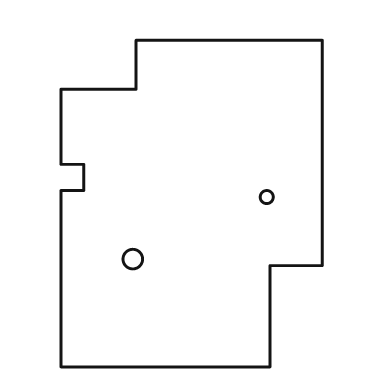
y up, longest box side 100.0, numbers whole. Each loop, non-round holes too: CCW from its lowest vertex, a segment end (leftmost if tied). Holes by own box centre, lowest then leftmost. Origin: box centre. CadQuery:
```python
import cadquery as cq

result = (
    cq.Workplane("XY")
    .moveTo(-40.0, -50.0)
    .lineTo(24.0, -50.0)
    .lineTo(24.0, -19.0)
    .lineTo(40.0, -19.0)
    .lineTo(40.0, 50.0)
    .lineTo(-17.0, 50.0)
    .lineTo(-17.0, 35.0)
    .lineTo(-40.0, 35.0)
    .lineTo(-40.0, 12.0)
    .lineTo(-33.0, 12.0)
    .lineTo(-33.0, 4.0)
    .lineTo(-40.0, 4.0)
    .close()
    .moveTo(-18.0, -17.0)
    .circle(3.0)
    .moveTo(23.0, 2.0)
    .circle(2.0)
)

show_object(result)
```